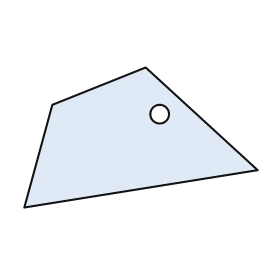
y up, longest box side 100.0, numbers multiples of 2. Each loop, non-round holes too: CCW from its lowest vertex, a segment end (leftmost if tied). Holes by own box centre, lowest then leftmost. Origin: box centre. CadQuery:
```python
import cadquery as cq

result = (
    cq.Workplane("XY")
    .moveTo(-50.0, -30.0)
    .lineTo(50.0, -14.0)
    .lineTo(2.0, 30.0)
    .lineTo(-38.0, 14.0)
    .close()
    .moveTo(8.0, 10.0)
    .circle(4.0)
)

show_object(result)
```